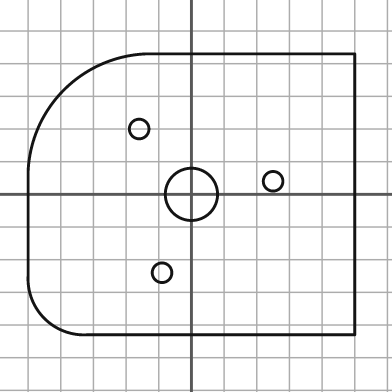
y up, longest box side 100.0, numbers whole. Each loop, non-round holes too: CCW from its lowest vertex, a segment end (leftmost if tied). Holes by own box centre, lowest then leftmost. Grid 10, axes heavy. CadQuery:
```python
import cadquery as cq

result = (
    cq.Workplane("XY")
    .moveTo(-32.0, -43.0)
    .lineTo(50.0, -43.0)
    .lineTo(50.0, 43.0)
    .lineTo(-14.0, 43.0)
    .threePointArc((-39.0, 32.0), (-50.0, 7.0))
    .lineTo(-50.0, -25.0)
    .threePointArc((-45.0, -38.0), (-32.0, -43.0))
    .close()
    .moveTo(-9.0, -24.0)
    .circle(3.0)
    .moveTo(0.0, 0.0)
    .circle(8.0)
    .moveTo(25.0, 4.0)
    .circle(3.0)
    .moveTo(-16.0, 20.0)
    .circle(3.0)
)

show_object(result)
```